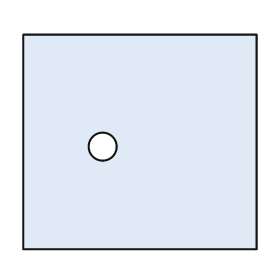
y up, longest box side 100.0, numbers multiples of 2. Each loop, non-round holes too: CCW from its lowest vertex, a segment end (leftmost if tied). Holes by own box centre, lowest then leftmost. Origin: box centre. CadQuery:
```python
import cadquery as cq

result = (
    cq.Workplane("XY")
    .moveTo(-50.0, -46.0)
    .lineTo(50.0, -46.0)
    .lineTo(50.0, 46.0)
    .lineTo(-50.0, 46.0)
    .close()
    .moveTo(-16.0, -2.0)
    .circle(6.0)
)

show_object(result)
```